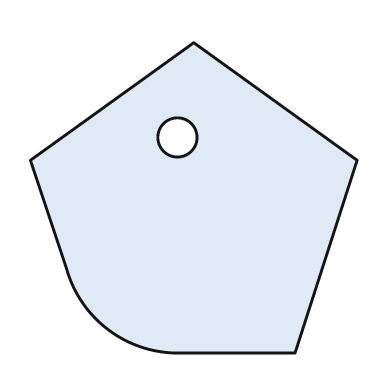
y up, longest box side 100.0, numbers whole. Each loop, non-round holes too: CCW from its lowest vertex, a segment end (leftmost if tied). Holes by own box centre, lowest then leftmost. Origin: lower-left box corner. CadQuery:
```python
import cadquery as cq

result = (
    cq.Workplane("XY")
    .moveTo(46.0, 0.0)
    .lineTo(81.0, 0.0)
    .lineTo(100.0, 59.0)
    .lineTo(50.0, 95.0)
    .lineTo(0.0, 59.0)
    .lineTo(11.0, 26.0)
    .threePointArc((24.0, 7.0), (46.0, 0.0))
    .close()
    .moveTo(45.0, 66.0)
    .circle(6.0)
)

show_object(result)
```